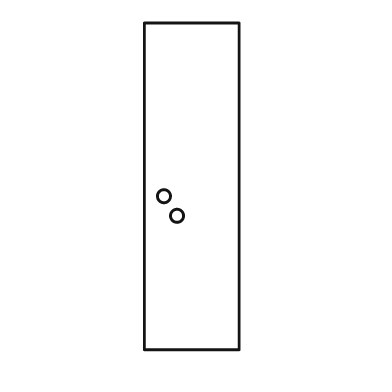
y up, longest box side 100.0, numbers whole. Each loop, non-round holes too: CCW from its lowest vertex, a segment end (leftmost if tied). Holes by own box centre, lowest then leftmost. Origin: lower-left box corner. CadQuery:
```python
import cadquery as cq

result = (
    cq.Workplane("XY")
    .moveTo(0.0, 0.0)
    .lineTo(29.0, 0.0)
    .lineTo(29.0, 100.0)
    .lineTo(0.0, 100.0)
    .close()
    .moveTo(10.0, 41.0)
    .circle(2.0)
    .moveTo(6.0, 47.0)
    .circle(2.0)
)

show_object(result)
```